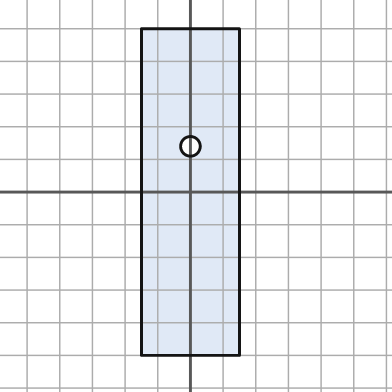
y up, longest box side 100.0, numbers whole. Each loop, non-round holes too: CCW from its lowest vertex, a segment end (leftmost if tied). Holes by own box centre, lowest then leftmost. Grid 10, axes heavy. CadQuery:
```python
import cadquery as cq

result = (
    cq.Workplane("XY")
    .moveTo(-15.0, -50.0)
    .lineTo(15.0, -50.0)
    .lineTo(15.0, 50.0)
    .lineTo(-15.0, 50.0)
    .close()
    .moveTo(0.0, 14.0)
    .circle(3.0)
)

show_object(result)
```